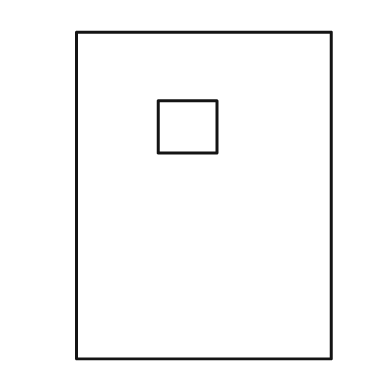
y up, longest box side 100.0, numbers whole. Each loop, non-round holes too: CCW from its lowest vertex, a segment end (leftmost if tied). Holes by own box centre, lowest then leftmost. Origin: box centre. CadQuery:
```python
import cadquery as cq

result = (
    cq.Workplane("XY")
    .moveTo(-39.0, -50.0)
    .lineTo(39.0, -50.0)
    .lineTo(39.0, 50.0)
    .lineTo(-39.0, 50.0)
    .close()
    .moveTo(-14.0, 13.0)
    .lineTo(4.0, 13.0)
    .lineTo(4.0, 29.0)
    .lineTo(-14.0, 29.0)
    .close()
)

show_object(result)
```